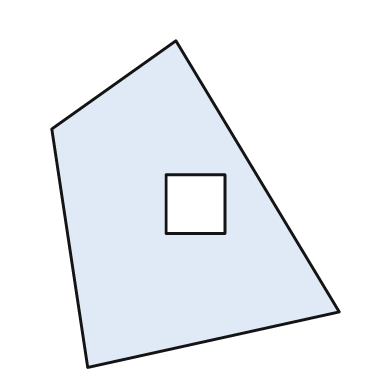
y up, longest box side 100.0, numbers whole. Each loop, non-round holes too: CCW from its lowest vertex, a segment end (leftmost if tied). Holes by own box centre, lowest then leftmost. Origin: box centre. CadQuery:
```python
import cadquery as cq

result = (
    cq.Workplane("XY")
    .moveTo(-33.0, -50.0)
    .lineTo(44.0, -33.0)
    .lineTo(-6.0, 50.0)
    .lineTo(-44.0, 23.0)
    .close()
    .moveTo(-9.0, -9.0)
    .lineTo(9.0, -9.0)
    .lineTo(9.0, 9.0)
    .lineTo(-9.0, 9.0)
    .close()
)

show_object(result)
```